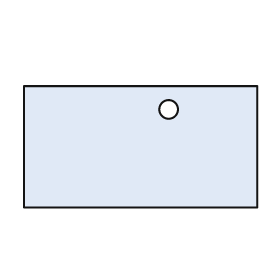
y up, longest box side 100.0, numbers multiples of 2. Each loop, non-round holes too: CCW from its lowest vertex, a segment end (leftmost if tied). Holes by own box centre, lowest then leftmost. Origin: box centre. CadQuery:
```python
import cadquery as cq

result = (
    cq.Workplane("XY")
    .moveTo(-50.0, -26.0)
    .lineTo(50.0, -26.0)
    .lineTo(50.0, 26.0)
    .lineTo(-50.0, 26.0)
    .close()
    .moveTo(12.0, 16.0)
    .circle(4.0)
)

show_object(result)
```